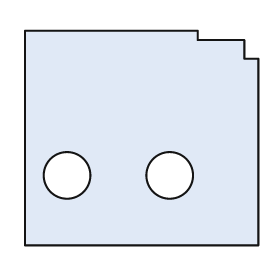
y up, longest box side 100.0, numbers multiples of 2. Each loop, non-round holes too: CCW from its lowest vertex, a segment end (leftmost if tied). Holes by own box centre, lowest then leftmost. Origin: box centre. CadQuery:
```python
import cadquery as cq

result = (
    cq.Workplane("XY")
    .moveTo(-50.0, -46.0)
    .lineTo(50.0, -46.0)
    .lineTo(50.0, 34.0)
    .lineTo(44.0, 34.0)
    .lineTo(44.0, 42.0)
    .lineTo(24.0, 42.0)
    .lineTo(24.0, 46.0)
    .lineTo(-50.0, 46.0)
    .close()
    .moveTo(-32.0, -16.0)
    .circle(10.0)
    .moveTo(12.0, -16.0)
    .circle(10.0)
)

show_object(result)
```